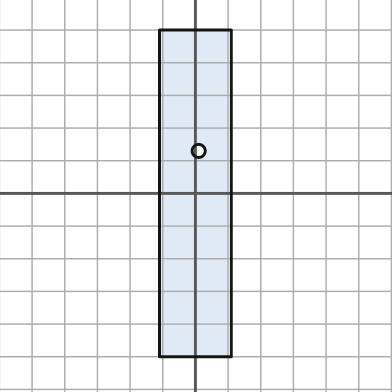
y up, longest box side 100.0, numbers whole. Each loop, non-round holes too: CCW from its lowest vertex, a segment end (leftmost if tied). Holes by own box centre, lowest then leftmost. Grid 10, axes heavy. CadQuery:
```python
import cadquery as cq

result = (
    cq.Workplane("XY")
    .moveTo(-11.0, -50.0)
    .lineTo(11.0, -50.0)
    .lineTo(11.0, 50.0)
    .lineTo(-11.0, 50.0)
    .close()
    .moveTo(1.0, 13.0)
    .circle(2.0)
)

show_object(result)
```